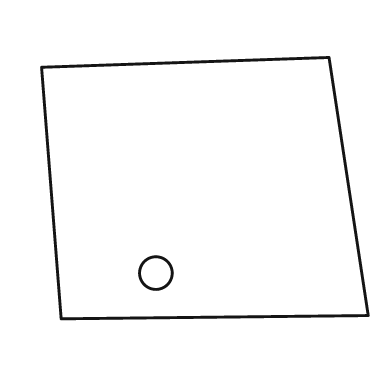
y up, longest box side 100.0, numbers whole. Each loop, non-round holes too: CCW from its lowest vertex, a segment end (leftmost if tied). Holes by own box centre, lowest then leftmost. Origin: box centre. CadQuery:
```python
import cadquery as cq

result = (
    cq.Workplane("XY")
    .moveTo(-44.0, -40.0)
    .lineTo(50.0, -39.0)
    .lineTo(38.0, 40.0)
    .lineTo(-50.0, 37.0)
    .close()
    .moveTo(-15.0, -26.0)
    .circle(5.0)
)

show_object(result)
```